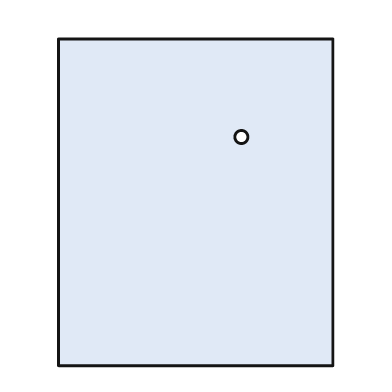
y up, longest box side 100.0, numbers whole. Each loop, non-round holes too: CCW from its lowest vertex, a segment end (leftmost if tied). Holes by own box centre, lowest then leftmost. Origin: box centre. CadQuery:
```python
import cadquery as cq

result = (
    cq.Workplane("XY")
    .moveTo(-42.0, -50.0)
    .lineTo(42.0, -50.0)
    .lineTo(42.0, 50.0)
    .lineTo(-42.0, 50.0)
    .close()
    .moveTo(14.0, 20.0)
    .circle(2.0)
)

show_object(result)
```